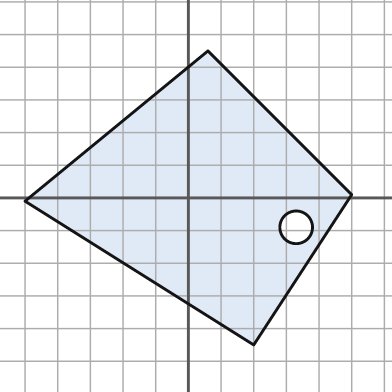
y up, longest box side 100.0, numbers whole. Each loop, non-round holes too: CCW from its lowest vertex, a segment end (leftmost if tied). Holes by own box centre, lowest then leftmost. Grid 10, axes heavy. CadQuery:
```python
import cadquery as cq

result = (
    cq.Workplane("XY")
    .moveTo(20.0, -45.0)
    .lineTo(50.0, 1.0)
    .lineTo(6.0, 45.0)
    .lineTo(-50.0, -1.0)
    .close()
    .moveTo(33.0, -9.0)
    .circle(5.0)
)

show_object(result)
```